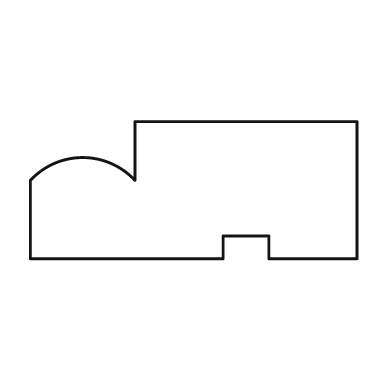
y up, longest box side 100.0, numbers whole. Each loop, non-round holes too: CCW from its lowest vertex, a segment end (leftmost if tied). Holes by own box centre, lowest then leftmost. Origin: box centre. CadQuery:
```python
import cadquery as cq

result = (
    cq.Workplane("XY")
    .moveTo(-50.0, -21.0)
    .lineTo(9.0, -21.0)
    .lineTo(9.0, -14.0)
    .lineTo(23.0, -14.0)
    .lineTo(23.0, -21.0)
    .lineTo(50.0, -21.0)
    .lineTo(50.0, 21.0)
    .lineTo(-18.0, 21.0)
    .lineTo(-18.0, 3.0)
    .threePointArc((-34.0, 10.0), (-50.0, 3.0))
    .close()
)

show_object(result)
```